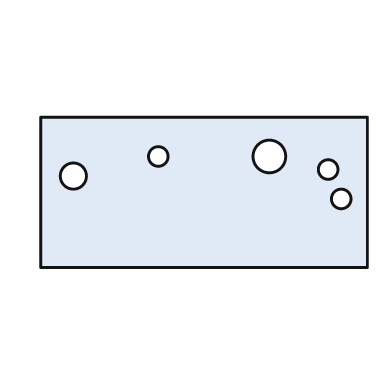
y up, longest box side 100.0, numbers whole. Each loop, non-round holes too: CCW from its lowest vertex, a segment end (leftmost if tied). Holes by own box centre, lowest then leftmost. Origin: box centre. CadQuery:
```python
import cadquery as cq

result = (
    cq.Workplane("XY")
    .moveTo(-50.0, -23.0)
    .lineTo(50.0, -23.0)
    .lineTo(50.0, 23.0)
    .lineTo(-50.0, 23.0)
    .close()
    .moveTo(42.0, -2.0)
    .circle(3.0)
    .moveTo(-40.0, 5.0)
    .circle(4.0)
    .moveTo(38.0, 7.0)
    .circle(3.0)
    .moveTo(-14.0, 11.0)
    .circle(3.0)
    .moveTo(20.0, 11.0)
    .circle(5.0)
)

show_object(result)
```